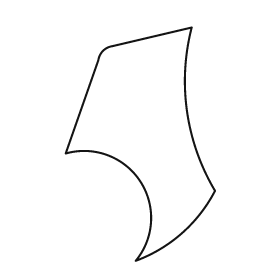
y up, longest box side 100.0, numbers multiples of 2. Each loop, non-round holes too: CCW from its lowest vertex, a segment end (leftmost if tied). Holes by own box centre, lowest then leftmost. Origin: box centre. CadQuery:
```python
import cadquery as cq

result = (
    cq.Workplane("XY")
    .moveTo(-2.0, -50.0)
    .threePointArc((18.0, -38.0), (32.0, -20.0))
    .threePointArc((20.0, 14.0), (22.0, 50.0))
    .lineTo(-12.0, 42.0)
    .threePointArc((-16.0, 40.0), (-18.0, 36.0))
    .lineTo(-32.0, -4.0)
    .threePointArc((0.0, -16.0), (-2.0, -50.0))
    .close()
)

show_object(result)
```